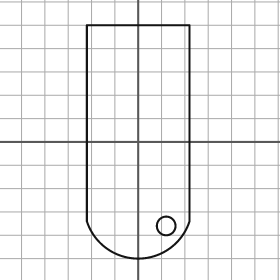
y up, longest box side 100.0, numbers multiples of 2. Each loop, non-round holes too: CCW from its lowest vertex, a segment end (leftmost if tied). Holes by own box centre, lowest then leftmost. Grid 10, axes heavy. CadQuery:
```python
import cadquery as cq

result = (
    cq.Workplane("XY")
    .moveTo(-22.0, -34.0)
    .threePointArc((0.0, -50.0), (22.0, -34.0))
    .lineTo(22.0, 50.0)
    .lineTo(-22.0, 50.0)
    .close()
    .moveTo(12.0, -36.0)
    .circle(4.0)
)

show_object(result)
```